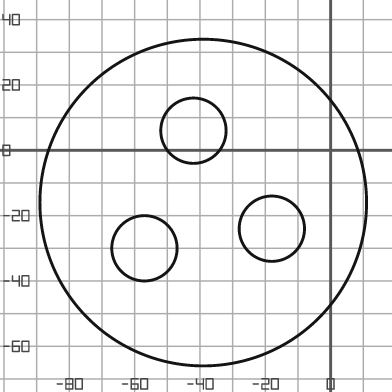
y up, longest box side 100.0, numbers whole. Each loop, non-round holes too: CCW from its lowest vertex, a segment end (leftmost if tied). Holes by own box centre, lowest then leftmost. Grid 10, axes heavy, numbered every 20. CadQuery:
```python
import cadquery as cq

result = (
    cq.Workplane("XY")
    .moveTo(-39.0, -16.0)
    .circle(50.0)
    .moveTo(-57.0, -30.0)
    .circle(10.0)
    .moveTo(-18.0, -24.0)
    .circle(10.0)
    .moveTo(-42.0, 6.0)
    .circle(10.0)
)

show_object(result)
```